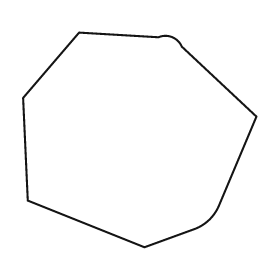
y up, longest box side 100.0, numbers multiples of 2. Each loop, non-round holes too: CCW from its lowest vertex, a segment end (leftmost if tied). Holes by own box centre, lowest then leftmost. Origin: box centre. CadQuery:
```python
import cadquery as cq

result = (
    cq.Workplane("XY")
    .moveTo(2.0, -46.0)
    .lineTo(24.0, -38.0)
    .threePointArc((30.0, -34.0), (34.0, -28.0))
    .lineTo(50.0, 10.0)
    .lineTo(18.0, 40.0)
    .threePointArc((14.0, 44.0), (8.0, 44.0))
    .lineTo(-26.0, 46.0)
    .lineTo(-50.0, 18.0)
    .lineTo(-48.0, -26.0)
    .close()
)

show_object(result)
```